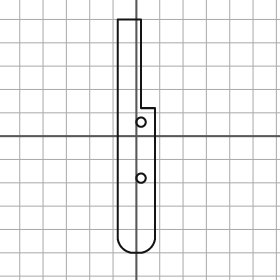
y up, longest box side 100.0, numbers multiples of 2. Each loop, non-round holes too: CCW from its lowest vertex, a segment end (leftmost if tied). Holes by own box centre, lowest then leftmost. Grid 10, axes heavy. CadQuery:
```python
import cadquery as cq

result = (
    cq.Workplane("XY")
    .moveTo(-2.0, -50.0)
    .lineTo(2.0, -50.0)
    .threePointArc((6.0, -48.0), (8.0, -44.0))
    .lineTo(8.0, 12.0)
    .lineTo(2.0, 12.0)
    .lineTo(2.0, 50.0)
    .lineTo(-8.0, 50.0)
    .lineTo(-8.0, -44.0)
    .threePointArc((-6.0, -48.0), (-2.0, -50.0))
    .close()
    .moveTo(2.0, -18.0)
    .circle(2.0)
    .moveTo(2.0, 6.0)
    .circle(2.0)
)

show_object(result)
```